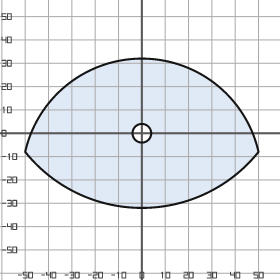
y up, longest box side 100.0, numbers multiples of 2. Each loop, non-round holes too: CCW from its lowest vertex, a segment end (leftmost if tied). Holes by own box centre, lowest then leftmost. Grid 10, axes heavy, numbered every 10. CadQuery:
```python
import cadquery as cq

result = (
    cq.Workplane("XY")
    .moveTo(-50.0, -8.0)
    .threePointArc((0.0, -32.0), (50.0, -8.0))
    .threePointArc((0.0, 32.0), (-50.0, -8.0))
    .close()
    .moveTo(0.0, 0.0)
    .circle(4.0)
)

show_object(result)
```